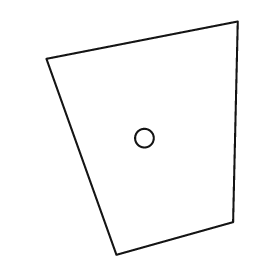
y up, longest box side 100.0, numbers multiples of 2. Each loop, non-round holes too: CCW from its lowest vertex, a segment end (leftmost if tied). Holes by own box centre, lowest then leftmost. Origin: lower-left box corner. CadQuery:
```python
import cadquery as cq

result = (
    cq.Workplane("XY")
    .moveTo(30.0, 0.0)
    .lineTo(80.0, 14.0)
    .lineTo(82.0, 100.0)
    .lineTo(0.0, 84.0)
    .close()
    .moveTo(42.0, 50.0)
    .circle(4.0)
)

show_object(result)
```